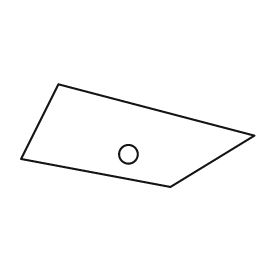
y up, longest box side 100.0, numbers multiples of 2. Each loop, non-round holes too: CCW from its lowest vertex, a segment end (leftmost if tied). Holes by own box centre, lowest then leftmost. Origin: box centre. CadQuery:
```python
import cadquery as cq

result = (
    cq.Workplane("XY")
    .moveTo(14.0, -22.0)
    .lineTo(50.0, 0.0)
    .lineTo(-34.0, 22.0)
    .lineTo(-50.0, -10.0)
    .close()
    .moveTo(-4.0, -8.0)
    .circle(4.0)
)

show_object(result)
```